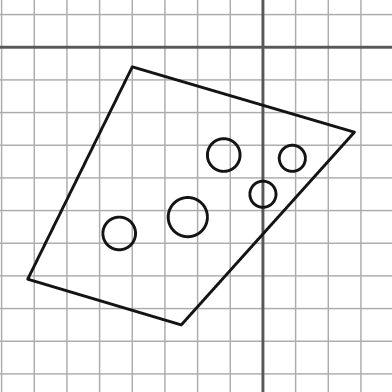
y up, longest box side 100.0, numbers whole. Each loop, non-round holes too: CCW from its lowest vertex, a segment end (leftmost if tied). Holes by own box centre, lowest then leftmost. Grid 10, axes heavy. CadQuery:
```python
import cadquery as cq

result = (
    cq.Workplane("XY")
    .moveTo(-25.0, -85.0)
    .lineTo(28.0, -26.0)
    .lineTo(-40.0, -6.0)
    .lineTo(-72.0, -71.0)
    .close()
    .moveTo(-44.0, -57.0)
    .circle(5.0)
    .moveTo(-23.0, -52.0)
    .circle(6.0)
    .moveTo(0.0, -45.0)
    .circle(4.0)
    .moveTo(9.0, -34.0)
    .circle(4.0)
    .moveTo(-12.0, -33.0)
    .circle(5.0)
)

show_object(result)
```